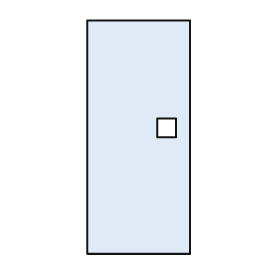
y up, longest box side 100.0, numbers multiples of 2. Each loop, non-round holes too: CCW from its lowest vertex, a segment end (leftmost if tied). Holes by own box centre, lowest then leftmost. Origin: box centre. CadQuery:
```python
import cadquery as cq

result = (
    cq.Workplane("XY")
    .moveTo(-22.0, -50.0)
    .lineTo(22.0, -50.0)
    .lineTo(22.0, 50.0)
    .lineTo(-22.0, 50.0)
    .close()
    .moveTo(8.0, 0.0)
    .lineTo(16.0, 0.0)
    .lineTo(16.0, 8.0)
    .lineTo(8.0, 8.0)
    .close()
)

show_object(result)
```